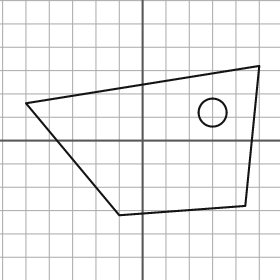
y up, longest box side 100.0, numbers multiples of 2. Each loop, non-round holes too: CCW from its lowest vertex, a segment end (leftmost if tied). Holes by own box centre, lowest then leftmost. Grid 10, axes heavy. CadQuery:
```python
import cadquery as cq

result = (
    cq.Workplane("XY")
    .moveTo(-10.0, -32.0)
    .lineTo(44.0, -28.0)
    .lineTo(50.0, 32.0)
    .lineTo(-50.0, 16.0)
    .close()
    .moveTo(30.0, 12.0)
    .circle(6.0)
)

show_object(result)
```